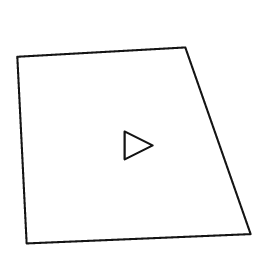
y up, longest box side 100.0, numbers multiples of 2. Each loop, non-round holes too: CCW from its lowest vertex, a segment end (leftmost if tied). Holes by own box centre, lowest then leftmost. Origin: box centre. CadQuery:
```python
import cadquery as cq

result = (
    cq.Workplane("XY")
    .moveTo(-46.0, -42.0)
    .lineTo(50.0, -38.0)
    .lineTo(22.0, 42.0)
    .lineTo(-50.0, 38.0)
    .close()
    .moveTo(-4.0, -6.0)
    .lineTo(8.0, 0.0)
    .lineTo(-4.0, 6.0)
    .close()
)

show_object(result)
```